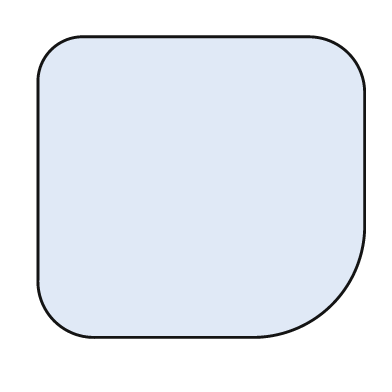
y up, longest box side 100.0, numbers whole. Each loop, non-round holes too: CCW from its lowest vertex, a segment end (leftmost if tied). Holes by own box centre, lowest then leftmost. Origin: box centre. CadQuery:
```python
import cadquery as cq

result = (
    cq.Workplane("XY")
    .moveTo(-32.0, -46.0)
    .lineTo(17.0, -46.0)
    .threePointArc((40.0, -36.0), (50.0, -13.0))
    .lineTo(50.0, 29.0)
    .threePointArc((45.0, 41.0), (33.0, 46.0))
    .lineTo(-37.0, 46.0)
    .threePointArc((-46.0, 42.0), (-50.0, 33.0))
    .lineTo(-50.0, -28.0)
    .threePointArc((-45.0, -41.0), (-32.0, -46.0))
    .close()
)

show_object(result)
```